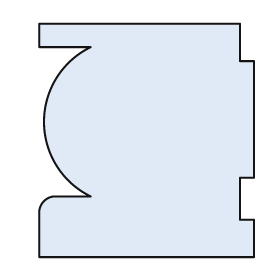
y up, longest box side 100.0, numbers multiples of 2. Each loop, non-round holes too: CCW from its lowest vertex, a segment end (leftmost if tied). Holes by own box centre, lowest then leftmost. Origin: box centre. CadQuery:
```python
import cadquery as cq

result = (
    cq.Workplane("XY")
    .moveTo(-46.0, -50.0)
    .lineTo(46.0, -50.0)
    .lineTo(46.0, -34.0)
    .lineTo(40.0, -34.0)
    .lineTo(40.0, -16.0)
    .lineTo(46.0, -16.0)
    .lineTo(46.0, 34.0)
    .lineTo(40.0, 34.0)
    .lineTo(40.0, 50.0)
    .lineTo(-46.0, 50.0)
    .lineTo(-46.0, 40.0)
    .lineTo(-24.0, 40.0)
    .threePointArc((-44.0, 8.0), (-24.0, -24.0))
    .lineTo(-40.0, -24.0)
    .threePointArc((-44.0, -26.0), (-46.0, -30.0))
    .close()
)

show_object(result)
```